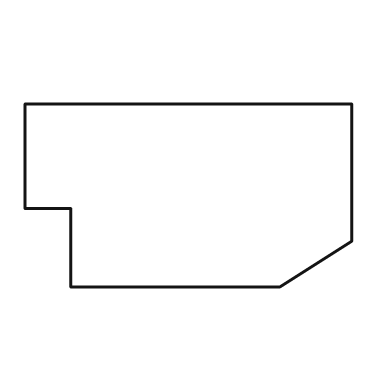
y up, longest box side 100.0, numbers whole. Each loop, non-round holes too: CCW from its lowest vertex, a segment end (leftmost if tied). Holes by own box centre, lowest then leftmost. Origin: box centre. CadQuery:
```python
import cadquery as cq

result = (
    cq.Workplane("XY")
    .moveTo(-36.0, -28.0)
    .lineTo(28.0, -28.0)
    .lineTo(50.0, -14.0)
    .lineTo(50.0, 28.0)
    .lineTo(-50.0, 28.0)
    .lineTo(-50.0, -4.0)
    .lineTo(-36.0, -4.0)
    .close()
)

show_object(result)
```